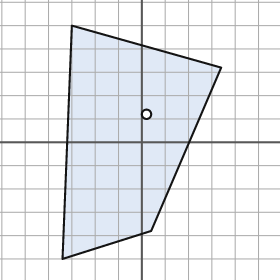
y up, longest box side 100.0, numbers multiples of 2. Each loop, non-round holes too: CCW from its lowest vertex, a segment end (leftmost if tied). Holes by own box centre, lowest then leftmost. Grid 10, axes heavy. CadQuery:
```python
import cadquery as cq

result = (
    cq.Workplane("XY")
    .moveTo(-34.0, -50.0)
    .lineTo(4.0, -38.0)
    .lineTo(34.0, 32.0)
    .lineTo(-30.0, 50.0)
    .close()
    .moveTo(2.0, 12.0)
    .circle(2.0)
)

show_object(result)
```